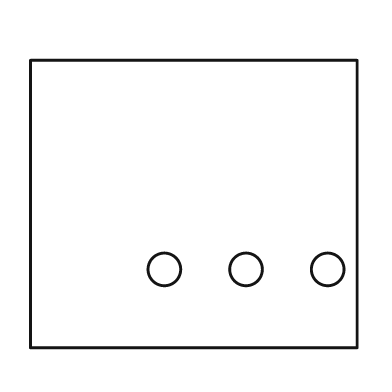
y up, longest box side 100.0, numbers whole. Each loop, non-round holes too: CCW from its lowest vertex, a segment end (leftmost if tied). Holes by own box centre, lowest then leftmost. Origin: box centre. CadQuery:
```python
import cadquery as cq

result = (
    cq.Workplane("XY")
    .moveTo(-50.0, -44.0)
    .lineTo(50.0, -44.0)
    .lineTo(50.0, 44.0)
    .lineTo(-50.0, 44.0)
    .close()
    .moveTo(-9.0, -20.0)
    .circle(5.0)
    .moveTo(16.0, -20.0)
    .circle(5.0)
    .moveTo(41.0, -20.0)
    .circle(5.0)
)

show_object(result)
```